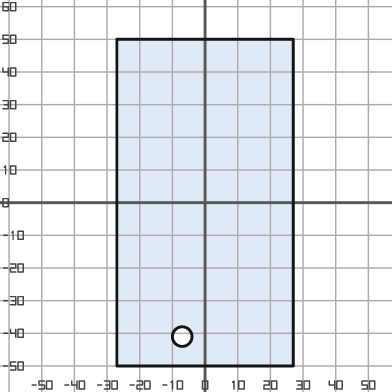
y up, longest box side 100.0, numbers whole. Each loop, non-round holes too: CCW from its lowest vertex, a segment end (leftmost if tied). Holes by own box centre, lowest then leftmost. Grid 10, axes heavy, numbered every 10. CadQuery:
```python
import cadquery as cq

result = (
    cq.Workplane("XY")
    .moveTo(-27.0, -50.0)
    .lineTo(27.0, -50.0)
    .lineTo(27.0, 50.0)
    .lineTo(-27.0, 50.0)
    .close()
    .moveTo(-7.0, -41.0)
    .circle(3.0)
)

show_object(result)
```